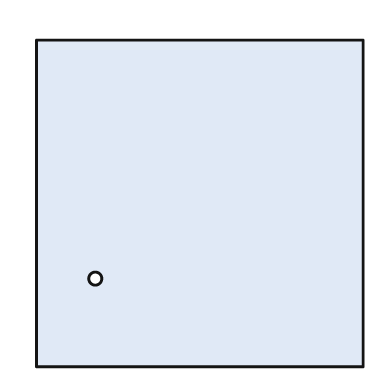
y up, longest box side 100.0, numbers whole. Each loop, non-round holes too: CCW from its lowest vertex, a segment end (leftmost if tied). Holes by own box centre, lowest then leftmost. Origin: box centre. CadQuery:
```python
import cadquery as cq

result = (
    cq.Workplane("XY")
    .moveTo(-50.0, -50.0)
    .lineTo(50.0, -50.0)
    .lineTo(50.0, 50.0)
    .lineTo(-50.0, 50.0)
    .close()
    .moveTo(-32.0, -23.0)
    .circle(2.0)
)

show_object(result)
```